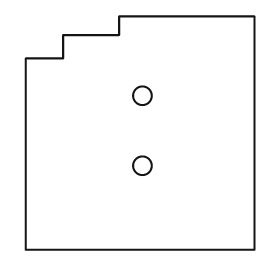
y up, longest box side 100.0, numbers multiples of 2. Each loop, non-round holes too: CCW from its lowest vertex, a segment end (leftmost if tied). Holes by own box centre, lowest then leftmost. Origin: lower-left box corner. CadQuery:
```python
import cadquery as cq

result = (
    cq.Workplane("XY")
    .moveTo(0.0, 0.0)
    .lineTo(98.0, 0.0)
    .lineTo(98.0, 100.0)
    .lineTo(40.0, 100.0)
    .lineTo(40.0, 92.0)
    .lineTo(16.0, 92.0)
    .lineTo(16.0, 82.0)
    .lineTo(0.0, 82.0)
    .close()
    .moveTo(50.0, 36.0)
    .circle(4.0)
    .moveTo(50.0, 66.0)
    .circle(4.0)
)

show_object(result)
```